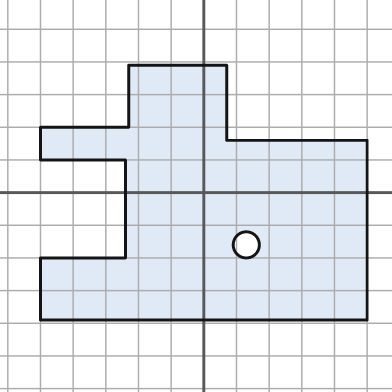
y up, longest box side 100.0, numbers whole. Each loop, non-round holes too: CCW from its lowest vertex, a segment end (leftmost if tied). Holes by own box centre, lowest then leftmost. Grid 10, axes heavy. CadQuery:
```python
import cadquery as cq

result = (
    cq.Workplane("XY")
    .moveTo(-50.0, -39.0)
    .lineTo(50.0, -39.0)
    .lineTo(50.0, 16.0)
    .lineTo(7.0, 16.0)
    .lineTo(7.0, 39.0)
    .lineTo(-23.0, 39.0)
    .lineTo(-23.0, 20.0)
    .lineTo(-50.0, 20.0)
    .lineTo(-50.0, 10.0)
    .lineTo(-24.0, 10.0)
    .lineTo(-24.0, -20.0)
    .lineTo(-50.0, -20.0)
    .close()
    .moveTo(13.0, -16.0)
    .circle(4.0)
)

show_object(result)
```